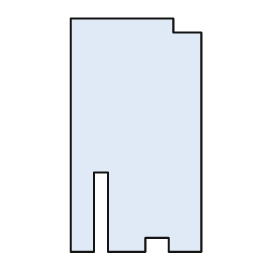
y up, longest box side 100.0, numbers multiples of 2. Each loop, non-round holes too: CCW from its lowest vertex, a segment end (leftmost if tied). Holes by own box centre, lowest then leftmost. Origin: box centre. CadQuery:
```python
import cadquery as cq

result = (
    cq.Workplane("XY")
    .moveTo(-28.0, -50.0)
    .lineTo(-18.0, -50.0)
    .lineTo(-18.0, -16.0)
    .lineTo(-12.0, -16.0)
    .lineTo(-12.0, -50.0)
    .lineTo(4.0, -50.0)
    .lineTo(4.0, -44.0)
    .lineTo(14.0, -44.0)
    .lineTo(14.0, -50.0)
    .lineTo(28.0, -50.0)
    .lineTo(28.0, 44.0)
    .lineTo(16.0, 44.0)
    .lineTo(16.0, 50.0)
    .lineTo(-28.0, 50.0)
    .close()
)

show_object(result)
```